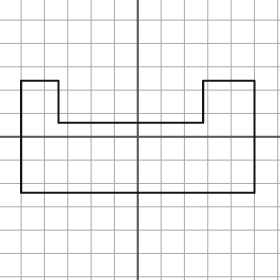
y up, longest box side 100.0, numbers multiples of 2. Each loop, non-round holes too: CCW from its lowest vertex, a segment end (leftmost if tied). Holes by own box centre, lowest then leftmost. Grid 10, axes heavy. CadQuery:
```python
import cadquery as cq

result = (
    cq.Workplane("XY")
    .moveTo(-50.0, -24.0)
    .lineTo(50.0, -24.0)
    .lineTo(50.0, 24.0)
    .lineTo(28.0, 24.0)
    .lineTo(28.0, 6.0)
    .lineTo(-34.0, 6.0)
    .lineTo(-34.0, 24.0)
    .lineTo(-50.0, 24.0)
    .close()
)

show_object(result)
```